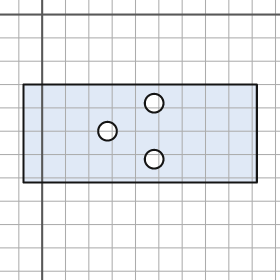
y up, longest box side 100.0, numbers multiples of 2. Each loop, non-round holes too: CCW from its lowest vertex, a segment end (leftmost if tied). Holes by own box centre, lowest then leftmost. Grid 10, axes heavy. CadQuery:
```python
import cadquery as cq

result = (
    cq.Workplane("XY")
    .moveTo(-8.0, -72.0)
    .lineTo(92.0, -72.0)
    .lineTo(92.0, -30.0)
    .lineTo(-8.0, -30.0)
    .close()
    .moveTo(48.0, -62.0)
    .circle(4.0)
    .moveTo(28.0, -50.0)
    .circle(4.0)
    .moveTo(48.0, -38.0)
    .circle(4.0)
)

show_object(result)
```